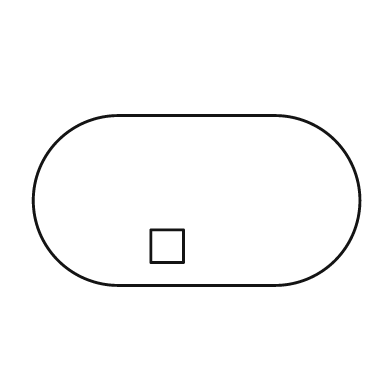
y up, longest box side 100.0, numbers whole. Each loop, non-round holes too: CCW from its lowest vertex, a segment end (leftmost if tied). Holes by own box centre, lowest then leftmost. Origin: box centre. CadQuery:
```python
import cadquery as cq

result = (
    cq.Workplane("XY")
    .moveTo(-24.0, -26.0)
    .lineTo(24.0, -26.0)
    .threePointArc((50.0, 0.0), (24.0, 26.0))
    .lineTo(-24.0, 26.0)
    .threePointArc((-50.0, 0.0), (-24.0, -26.0))
    .close()
    .moveTo(-14.0, -19.0)
    .lineTo(-4.0, -19.0)
    .lineTo(-4.0, -9.0)
    .lineTo(-14.0, -9.0)
    .close()
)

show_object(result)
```